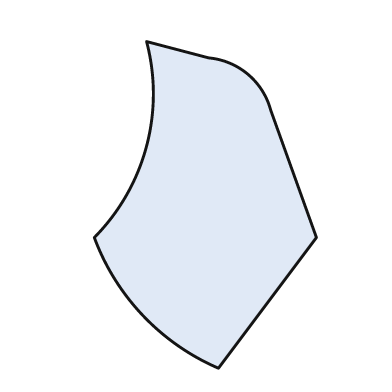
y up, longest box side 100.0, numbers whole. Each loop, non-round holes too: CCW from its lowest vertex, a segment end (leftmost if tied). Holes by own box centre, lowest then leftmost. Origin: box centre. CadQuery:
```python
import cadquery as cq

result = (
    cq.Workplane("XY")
    .moveTo(4.0, -50.0)
    .lineTo(34.0, -10.0)
    .lineTo(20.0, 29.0)
    .threePointArc((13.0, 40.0), (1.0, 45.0))
    .lineTo(-18.0, 50.0)
    .threePointArc((-18.0, 18.0), (-34.0, -10.0))
    .threePointArc((-19.0, -34.0), (4.0, -50.0))
    .close()
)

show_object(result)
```